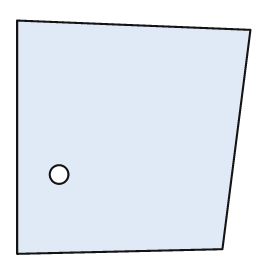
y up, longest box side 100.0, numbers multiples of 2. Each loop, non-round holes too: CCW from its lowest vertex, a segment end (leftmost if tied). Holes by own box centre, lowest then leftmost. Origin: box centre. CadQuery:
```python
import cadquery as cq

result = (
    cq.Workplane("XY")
    .moveTo(-50.0, -50.0)
    .lineTo(38.0, -48.0)
    .lineTo(50.0, 46.0)
    .lineTo(-50.0, 50.0)
    .close()
    .moveTo(-32.0, -16.0)
    .circle(4.0)
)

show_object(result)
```